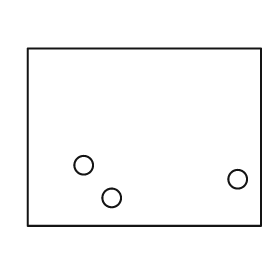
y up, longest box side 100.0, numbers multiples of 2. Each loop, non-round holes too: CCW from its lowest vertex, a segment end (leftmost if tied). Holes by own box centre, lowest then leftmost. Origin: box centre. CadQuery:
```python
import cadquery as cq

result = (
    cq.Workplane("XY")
    .moveTo(-50.0, -38.0)
    .lineTo(50.0, -38.0)
    .lineTo(50.0, 38.0)
    .lineTo(-50.0, 38.0)
    .close()
    .moveTo(-14.0, -26.0)
    .circle(4.0)
    .moveTo(40.0, -18.0)
    .circle(4.0)
    .moveTo(-26.0, -12.0)
    .circle(4.0)
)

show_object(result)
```